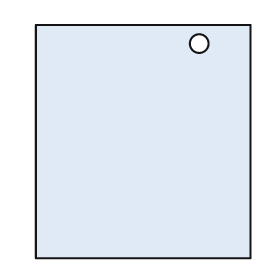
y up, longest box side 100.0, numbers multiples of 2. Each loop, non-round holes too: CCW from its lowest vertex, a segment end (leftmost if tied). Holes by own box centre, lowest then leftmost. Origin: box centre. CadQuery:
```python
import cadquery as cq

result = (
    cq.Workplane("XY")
    .moveTo(-46.0, -50.0)
    .lineTo(46.0, -50.0)
    .lineTo(46.0, 50.0)
    .lineTo(-46.0, 50.0)
    .close()
    .moveTo(24.0, 42.0)
    .circle(4.0)
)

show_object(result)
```